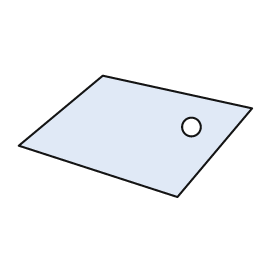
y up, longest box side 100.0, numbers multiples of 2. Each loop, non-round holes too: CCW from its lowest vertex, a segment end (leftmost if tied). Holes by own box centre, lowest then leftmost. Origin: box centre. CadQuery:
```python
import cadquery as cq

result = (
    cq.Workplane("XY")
    .moveTo(18.0, -26.0)
    .lineTo(50.0, 12.0)
    .lineTo(-14.0, 26.0)
    .lineTo(-50.0, -4.0)
    .close()
    .moveTo(24.0, 4.0)
    .circle(4.0)
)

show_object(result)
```